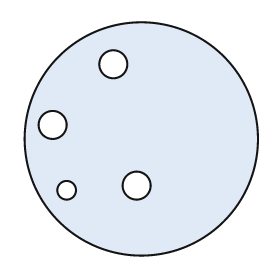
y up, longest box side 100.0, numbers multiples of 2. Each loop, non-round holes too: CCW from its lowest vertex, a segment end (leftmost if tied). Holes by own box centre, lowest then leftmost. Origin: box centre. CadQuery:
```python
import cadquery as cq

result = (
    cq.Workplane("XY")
    .moveTo(0.0, 0.0)
    .circle(50.0)
    .moveTo(-32.0, -22.0)
    .circle(4.0)
    .moveTo(-2.0, -20.0)
    .circle(6.0)
    .moveTo(-38.0, 6.0)
    .circle(6.0)
    .moveTo(-12.0, 32.0)
    .circle(6.0)
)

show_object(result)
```